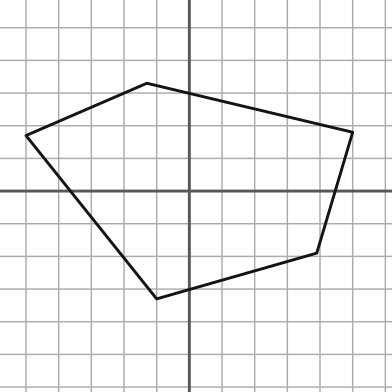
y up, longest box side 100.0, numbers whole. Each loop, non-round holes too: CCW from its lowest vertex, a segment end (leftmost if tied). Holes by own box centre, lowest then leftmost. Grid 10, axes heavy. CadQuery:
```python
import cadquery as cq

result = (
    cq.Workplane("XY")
    .moveTo(-10.0, -33.0)
    .lineTo(39.0, -19.0)
    .lineTo(50.0, 18.0)
    .lineTo(-13.0, 33.0)
    .lineTo(-50.0, 17.0)
    .close()
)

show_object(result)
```